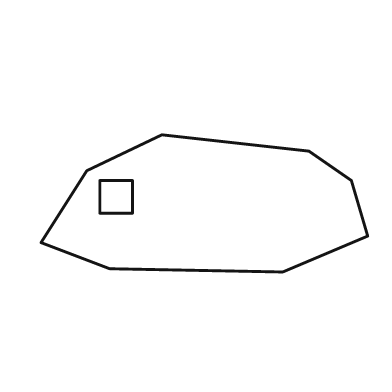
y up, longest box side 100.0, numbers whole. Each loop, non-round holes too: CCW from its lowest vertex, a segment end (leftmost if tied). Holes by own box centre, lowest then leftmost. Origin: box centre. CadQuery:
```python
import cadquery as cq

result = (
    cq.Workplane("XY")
    .moveTo(24.0, -21.0)
    .lineTo(50.0, -10.0)
    .lineTo(45.0, 7.0)
    .lineTo(32.0, 16.0)
    .lineTo(-13.0, 21.0)
    .lineTo(-36.0, 10.0)
    .lineTo(-50.0, -12.0)
    .lineTo(-29.0, -20.0)
    .close()
    .moveTo(-32.0, -3.0)
    .lineTo(-22.0, -3.0)
    .lineTo(-22.0, 7.0)
    .lineTo(-32.0, 7.0)
    .close()
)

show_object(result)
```